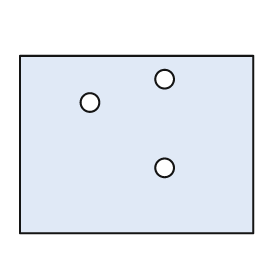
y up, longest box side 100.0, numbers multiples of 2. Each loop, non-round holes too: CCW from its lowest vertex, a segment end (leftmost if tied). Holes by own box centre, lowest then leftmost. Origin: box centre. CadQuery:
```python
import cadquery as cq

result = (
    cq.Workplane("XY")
    .moveTo(-50.0, -38.0)
    .lineTo(50.0, -38.0)
    .lineTo(50.0, 38.0)
    .lineTo(-50.0, 38.0)
    .close()
    .moveTo(12.0, -10.0)
    .circle(4.0)
    .moveTo(-20.0, 18.0)
    .circle(4.0)
    .moveTo(12.0, 28.0)
    .circle(4.0)
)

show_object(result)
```